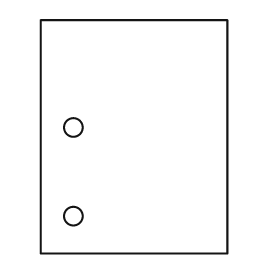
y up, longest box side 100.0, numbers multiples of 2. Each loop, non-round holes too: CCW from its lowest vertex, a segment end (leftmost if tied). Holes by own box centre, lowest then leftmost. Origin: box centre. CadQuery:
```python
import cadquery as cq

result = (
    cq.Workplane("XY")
    .moveTo(-40.0, -50.0)
    .lineTo(40.0, -50.0)
    .lineTo(40.0, 50.0)
    .lineTo(-40.0, 50.0)
    .close()
    .moveTo(-26.0, -34.0)
    .circle(4.0)
    .moveTo(-26.0, 4.0)
    .circle(4.0)
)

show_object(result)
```